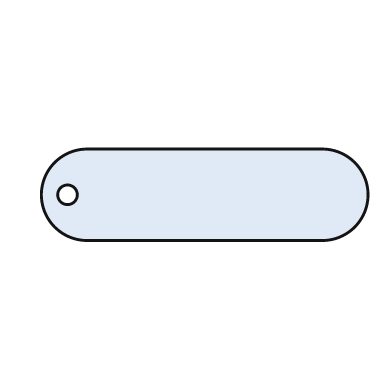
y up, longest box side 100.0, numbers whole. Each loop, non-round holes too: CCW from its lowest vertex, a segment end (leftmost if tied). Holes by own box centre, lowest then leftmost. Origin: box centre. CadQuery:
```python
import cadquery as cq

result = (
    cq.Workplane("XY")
    .moveTo(-36.0, -14.0)
    .lineTo(36.0, -14.0)
    .threePointArc((50.0, 0.0), (36.0, 14.0))
    .lineTo(-36.0, 14.0)
    .threePointArc((-50.0, 0.0), (-36.0, -14.0))
    .close()
    .moveTo(-42.0, 0.0)
    .circle(3.0)
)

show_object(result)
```